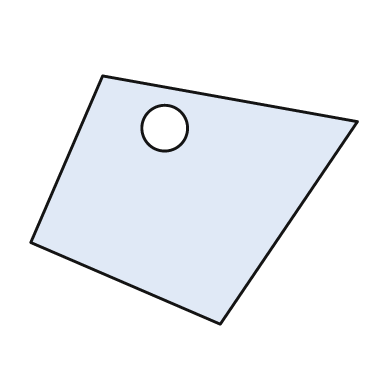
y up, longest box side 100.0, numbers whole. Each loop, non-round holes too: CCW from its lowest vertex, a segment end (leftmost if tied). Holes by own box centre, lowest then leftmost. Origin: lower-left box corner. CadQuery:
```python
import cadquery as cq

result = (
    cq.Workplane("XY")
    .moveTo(58.0, 0.0)
    .lineTo(100.0, 62.0)
    .lineTo(22.0, 76.0)
    .lineTo(0.0, 25.0)
    .close()
    .moveTo(41.0, 60.0)
    .circle(7.0)
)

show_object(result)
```